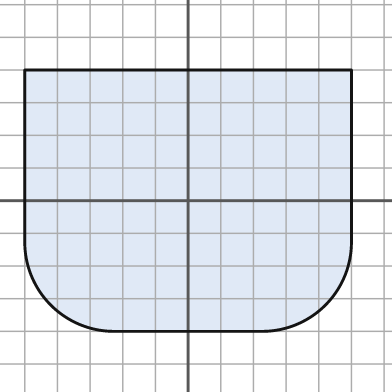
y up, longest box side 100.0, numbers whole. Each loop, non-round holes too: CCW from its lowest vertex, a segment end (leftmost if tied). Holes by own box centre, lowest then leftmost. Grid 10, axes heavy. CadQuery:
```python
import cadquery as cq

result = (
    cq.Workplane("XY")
    .moveTo(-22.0, -40.0)
    .lineTo(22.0, -40.0)
    .threePointArc((42.0, -32.0), (50.0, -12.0))
    .lineTo(50.0, 40.0)
    .lineTo(-50.0, 40.0)
    .lineTo(-50.0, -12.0)
    .threePointArc((-42.0, -32.0), (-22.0, -40.0))
    .close()
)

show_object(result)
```